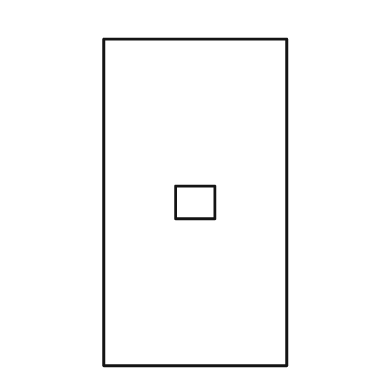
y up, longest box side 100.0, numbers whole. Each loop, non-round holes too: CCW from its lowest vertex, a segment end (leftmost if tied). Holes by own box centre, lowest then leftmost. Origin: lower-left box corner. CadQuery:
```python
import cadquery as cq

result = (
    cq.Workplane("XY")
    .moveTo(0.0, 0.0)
    .lineTo(56.0, 0.0)
    .lineTo(56.0, 100.0)
    .lineTo(0.0, 100.0)
    .close()
    .moveTo(22.0, 45.0)
    .lineTo(34.0, 45.0)
    .lineTo(34.0, 55.0)
    .lineTo(22.0, 55.0)
    .close()
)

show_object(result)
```